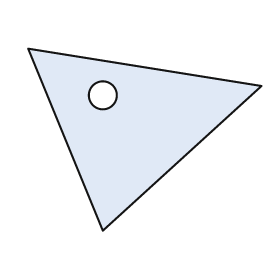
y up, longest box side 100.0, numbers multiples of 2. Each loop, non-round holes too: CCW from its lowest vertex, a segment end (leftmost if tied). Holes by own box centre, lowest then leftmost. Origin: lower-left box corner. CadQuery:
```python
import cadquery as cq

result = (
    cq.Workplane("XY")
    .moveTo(32.0, 0.0)
    .lineTo(100.0, 62.0)
    .lineTo(0.0, 78.0)
    .close()
    .moveTo(32.0, 58.0)
    .circle(6.0)
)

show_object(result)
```